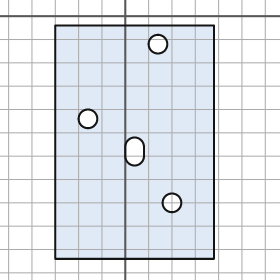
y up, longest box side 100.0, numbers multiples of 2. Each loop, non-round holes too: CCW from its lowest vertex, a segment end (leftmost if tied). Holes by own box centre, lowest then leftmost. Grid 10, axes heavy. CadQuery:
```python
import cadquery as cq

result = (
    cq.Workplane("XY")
    .moveTo(-30.0, -104.0)
    .lineTo(38.0, -104.0)
    .lineTo(38.0, -4.0)
    .lineTo(-30.0, -4.0)
    .close()
    .moveTo(20.0, -80.0)
    .circle(4.0)
    .moveTo(0.0, -60.0)
    .threePointArc((4.0, -64.0), (8.0, -60.0))
    .lineTo(8.0, -56.0)
    .threePointArc((4.0, -52.0), (0.0, -56.0))
    .close()
    .moveTo(-16.0, -44.0)
    .circle(4.0)
    .moveTo(14.0, -12.0)
    .circle(4.0)
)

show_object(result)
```